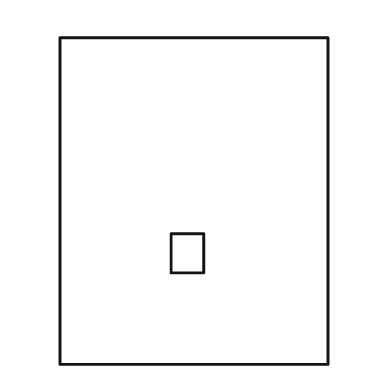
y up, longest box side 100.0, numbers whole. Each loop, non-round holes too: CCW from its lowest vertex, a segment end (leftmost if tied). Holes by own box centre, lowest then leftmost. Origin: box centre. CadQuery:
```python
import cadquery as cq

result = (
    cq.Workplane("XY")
    .moveTo(-41.0, -50.0)
    .lineTo(41.0, -50.0)
    .lineTo(41.0, 50.0)
    .lineTo(-41.0, 50.0)
    .close()
    .moveTo(-7.0, -22.0)
    .lineTo(3.0, -22.0)
    .lineTo(3.0, -10.0)
    .lineTo(-7.0, -10.0)
    .close()
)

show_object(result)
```